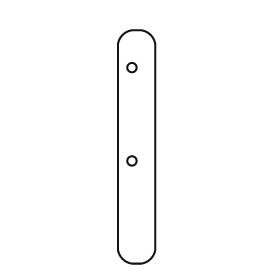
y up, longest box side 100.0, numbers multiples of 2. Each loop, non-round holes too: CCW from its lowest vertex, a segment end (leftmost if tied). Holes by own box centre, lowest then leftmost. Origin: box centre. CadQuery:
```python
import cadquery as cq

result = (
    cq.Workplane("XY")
    .moveTo(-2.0, -50.0)
    .lineTo(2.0, -50.0)
    .threePointArc((6.0, -48.0), (8.0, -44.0))
    .lineTo(8.0, 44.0)
    .threePointArc((6.0, 48.0), (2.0, 50.0))
    .lineTo(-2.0, 50.0)
    .threePointArc((-6.0, 48.0), (-8.0, 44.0))
    .lineTo(-8.0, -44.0)
    .threePointArc((-6.0, -48.0), (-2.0, -50.0))
    .close()
    .moveTo(-2.0, -6.0)
    .circle(2.0)
    .moveTo(-2.0, 34.0)
    .circle(2.0)
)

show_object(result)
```